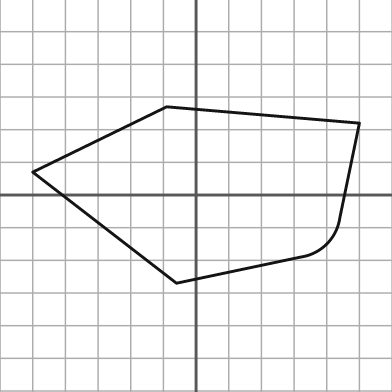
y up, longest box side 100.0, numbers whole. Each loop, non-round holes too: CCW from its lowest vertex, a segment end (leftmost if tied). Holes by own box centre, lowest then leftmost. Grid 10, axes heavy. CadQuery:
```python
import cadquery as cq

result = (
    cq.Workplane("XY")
    .moveTo(-6.0, -27.0)
    .lineTo(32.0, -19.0)
    .threePointArc((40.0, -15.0), (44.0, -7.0))
    .lineTo(50.0, 22.0)
    .lineTo(-9.0, 27.0)
    .lineTo(-50.0, 7.0)
    .close()
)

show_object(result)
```